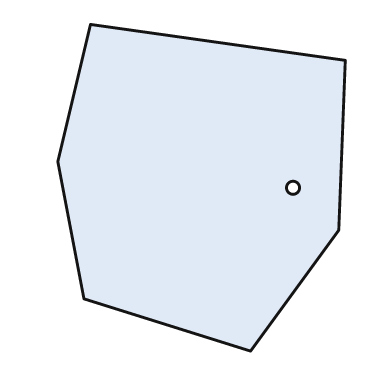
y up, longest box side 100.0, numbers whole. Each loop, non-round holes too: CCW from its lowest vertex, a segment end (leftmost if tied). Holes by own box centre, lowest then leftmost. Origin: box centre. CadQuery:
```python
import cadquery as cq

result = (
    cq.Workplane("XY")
    .moveTo(15.0, -50.0)
    .lineTo(42.0, -13.0)
    .lineTo(44.0, 39.0)
    .lineTo(-34.0, 50.0)
    .lineTo(-44.0, 8.0)
    .lineTo(-36.0, -34.0)
    .close()
    .moveTo(28.0, 0.0)
    .circle(2.0)
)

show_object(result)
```